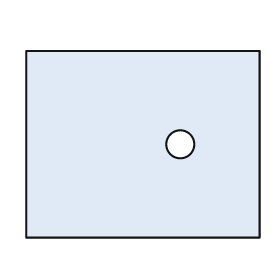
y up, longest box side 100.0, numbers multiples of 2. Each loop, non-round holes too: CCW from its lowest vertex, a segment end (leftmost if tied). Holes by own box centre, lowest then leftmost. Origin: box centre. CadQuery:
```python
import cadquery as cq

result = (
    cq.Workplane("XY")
    .moveTo(-50.0, -40.0)
    .lineTo(50.0, -40.0)
    .lineTo(50.0, 40.0)
    .lineTo(-50.0, 40.0)
    .close()
    .moveTo(16.0, 0.0)
    .circle(6.0)
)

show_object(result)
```